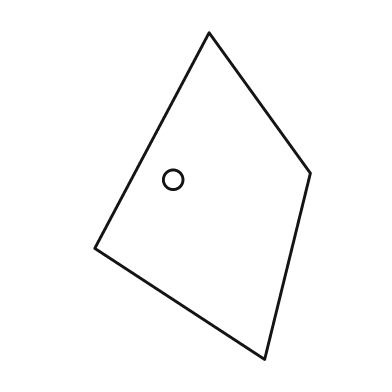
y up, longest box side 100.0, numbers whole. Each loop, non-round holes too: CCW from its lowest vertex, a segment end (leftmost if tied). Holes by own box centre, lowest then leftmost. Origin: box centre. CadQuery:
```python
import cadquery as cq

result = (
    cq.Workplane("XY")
    .moveTo(19.0, -50.0)
    .lineTo(33.0, 7.0)
    .lineTo(2.0, 50.0)
    .lineTo(-33.0, -16.0)
    .close()
    .moveTo(-9.0, 5.0)
    .circle(3.0)
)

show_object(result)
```